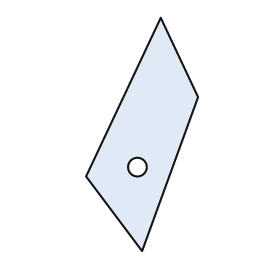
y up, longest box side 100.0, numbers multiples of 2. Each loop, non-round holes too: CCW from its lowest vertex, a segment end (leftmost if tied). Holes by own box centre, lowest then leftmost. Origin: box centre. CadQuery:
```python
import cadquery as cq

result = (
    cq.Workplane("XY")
    .moveTo(0.0, -50.0)
    .lineTo(24.0, 16.0)
    .lineTo(8.0, 50.0)
    .lineTo(-24.0, -18.0)
    .close()
    .moveTo(-2.0, -14.0)
    .circle(4.0)
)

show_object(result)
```